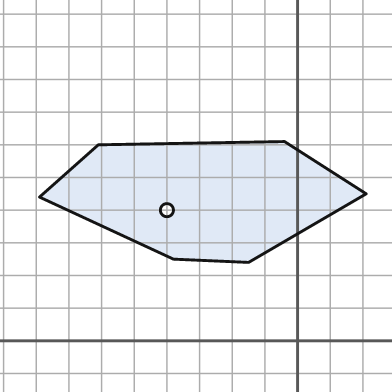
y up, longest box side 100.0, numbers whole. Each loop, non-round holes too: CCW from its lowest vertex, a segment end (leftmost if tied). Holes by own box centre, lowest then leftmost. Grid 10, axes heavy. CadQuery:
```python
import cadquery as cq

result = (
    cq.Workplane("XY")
    .moveTo(-15.0, 24.0)
    .lineTo(21.0, 45.0)
    .lineTo(-4.0, 61.0)
    .lineTo(-61.0, 60.0)
    .lineTo(-79.0, 44.0)
    .lineTo(-38.0, 25.0)
    .close()
    .moveTo(-40.0, 40.0)
    .circle(2.0)
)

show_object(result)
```